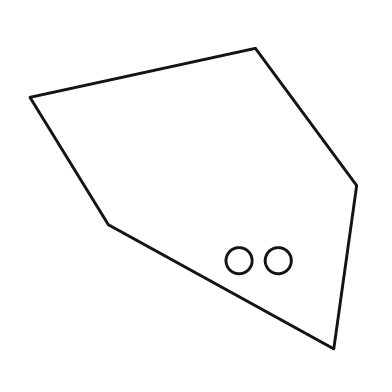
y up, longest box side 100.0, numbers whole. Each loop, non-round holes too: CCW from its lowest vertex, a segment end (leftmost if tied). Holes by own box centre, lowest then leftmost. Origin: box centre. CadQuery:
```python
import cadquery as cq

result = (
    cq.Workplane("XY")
    .moveTo(43.0, -46.0)
    .lineTo(50.0, 4.0)
    .lineTo(19.0, 46.0)
    .lineTo(-50.0, 31.0)
    .lineTo(-26.0, -8.0)
    .close()
    .moveTo(14.0, -19.0)
    .circle(4.0)
    .moveTo(26.0, -19.0)
    .circle(4.0)
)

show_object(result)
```